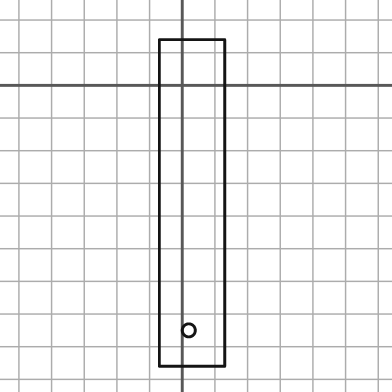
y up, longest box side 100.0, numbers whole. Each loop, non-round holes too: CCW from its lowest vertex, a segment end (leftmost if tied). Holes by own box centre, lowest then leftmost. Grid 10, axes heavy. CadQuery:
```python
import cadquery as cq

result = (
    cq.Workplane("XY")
    .moveTo(-7.0, -86.0)
    .lineTo(13.0, -86.0)
    .lineTo(13.0, 14.0)
    .lineTo(-7.0, 14.0)
    .close()
    .moveTo(2.0, -75.0)
    .circle(2.0)
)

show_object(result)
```